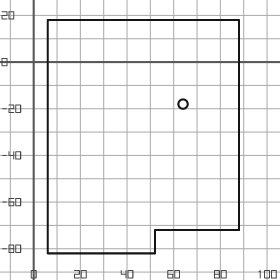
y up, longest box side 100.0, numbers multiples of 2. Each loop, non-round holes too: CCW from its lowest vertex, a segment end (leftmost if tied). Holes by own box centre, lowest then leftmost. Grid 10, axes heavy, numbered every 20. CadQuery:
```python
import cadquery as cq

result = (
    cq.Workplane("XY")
    .moveTo(6.0, -82.0)
    .lineTo(52.0, -82.0)
    .lineTo(52.0, -72.0)
    .lineTo(88.0, -72.0)
    .lineTo(88.0, 18.0)
    .lineTo(6.0, 18.0)
    .close()
    .moveTo(64.0, -18.0)
    .circle(2.0)
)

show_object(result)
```